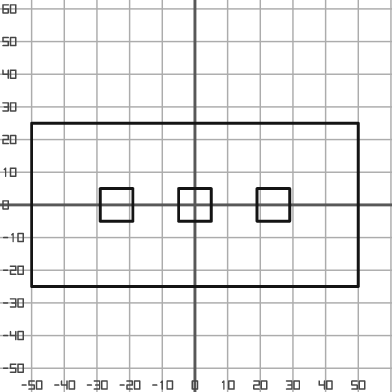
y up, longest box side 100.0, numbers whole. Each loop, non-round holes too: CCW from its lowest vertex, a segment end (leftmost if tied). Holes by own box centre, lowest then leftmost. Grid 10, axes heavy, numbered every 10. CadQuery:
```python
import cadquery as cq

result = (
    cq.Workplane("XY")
    .moveTo(-50.0, -25.0)
    .lineTo(50.0, -25.0)
    .lineTo(50.0, 25.0)
    .lineTo(-50.0, 25.0)
    .close()
    .moveTo(-29.0, -5.0)
    .lineTo(-19.0, -5.0)
    .lineTo(-19.0, 5.0)
    .lineTo(-29.0, 5.0)
    .close()
    .moveTo(-5.0, -5.0)
    .lineTo(5.0, -5.0)
    .lineTo(5.0, 5.0)
    .lineTo(-5.0, 5.0)
    .close()
    .moveTo(19.0, -5.0)
    .lineTo(29.0, -5.0)
    .lineTo(29.0, 5.0)
    .lineTo(19.0, 5.0)
    .close()
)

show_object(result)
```